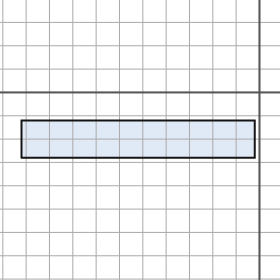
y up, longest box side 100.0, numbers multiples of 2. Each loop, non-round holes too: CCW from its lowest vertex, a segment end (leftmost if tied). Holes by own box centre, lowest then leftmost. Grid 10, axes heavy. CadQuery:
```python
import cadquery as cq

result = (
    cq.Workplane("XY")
    .moveTo(-102.0, -28.0)
    .lineTo(-2.0, -28.0)
    .lineTo(-2.0, -12.0)
    .lineTo(-102.0, -12.0)
    .close()
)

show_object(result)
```